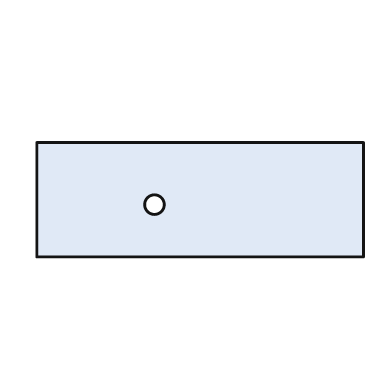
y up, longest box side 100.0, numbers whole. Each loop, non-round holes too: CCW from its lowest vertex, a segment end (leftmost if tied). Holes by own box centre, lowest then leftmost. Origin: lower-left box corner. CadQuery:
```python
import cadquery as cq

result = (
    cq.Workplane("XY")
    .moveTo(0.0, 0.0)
    .lineTo(100.0, 0.0)
    .lineTo(100.0, 35.0)
    .lineTo(0.0, 35.0)
    .close()
    .moveTo(36.0, 16.0)
    .circle(3.0)
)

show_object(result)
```